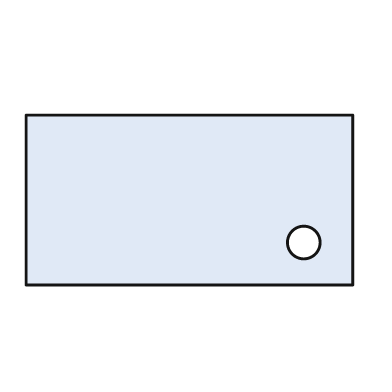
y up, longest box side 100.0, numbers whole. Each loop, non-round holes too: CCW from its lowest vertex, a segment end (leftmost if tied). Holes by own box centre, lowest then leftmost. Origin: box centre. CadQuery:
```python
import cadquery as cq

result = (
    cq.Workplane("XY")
    .moveTo(-50.0, -26.0)
    .lineTo(50.0, -26.0)
    .lineTo(50.0, 26.0)
    .lineTo(-50.0, 26.0)
    .close()
    .moveTo(35.0, -13.0)
    .circle(5.0)
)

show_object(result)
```